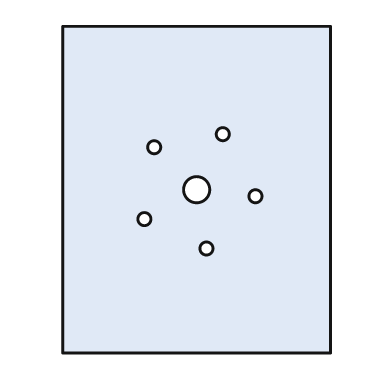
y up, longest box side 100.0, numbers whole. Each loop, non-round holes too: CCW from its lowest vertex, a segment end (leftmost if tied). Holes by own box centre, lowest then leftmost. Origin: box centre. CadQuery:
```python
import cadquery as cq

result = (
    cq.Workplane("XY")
    .moveTo(-41.0, -50.0)
    .lineTo(41.0, -50.0)
    .lineTo(41.0, 50.0)
    .lineTo(-41.0, 50.0)
    .close()
    .moveTo(3.0, -18.0)
    .circle(2.0)
    .moveTo(-16.0, -9.0)
    .circle(2.0)
    .moveTo(18.0, -2.0)
    .circle(2.0)
    .moveTo(0.0, 0.0)
    .circle(4.0)
    .moveTo(-13.0, 13.0)
    .circle(2.0)
    .moveTo(8.0, 17.0)
    .circle(2.0)
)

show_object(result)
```